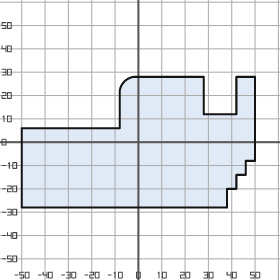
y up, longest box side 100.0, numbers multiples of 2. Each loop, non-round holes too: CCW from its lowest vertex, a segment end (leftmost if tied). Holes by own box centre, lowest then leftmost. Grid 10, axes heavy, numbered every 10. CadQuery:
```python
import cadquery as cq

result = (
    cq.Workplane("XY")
    .moveTo(-50.0, -28.0)
    .lineTo(38.0, -28.0)
    .lineTo(38.0, -20.0)
    .lineTo(42.0, -20.0)
    .lineTo(42.0, -14.0)
    .lineTo(46.0, -14.0)
    .lineTo(46.0, -8.0)
    .lineTo(50.0, -8.0)
    .lineTo(50.0, 28.0)
    .lineTo(42.0, 28.0)
    .lineTo(42.0, 12.0)
    .lineTo(28.0, 12.0)
    .lineTo(28.0, 28.0)
    .lineTo(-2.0, 28.0)
    .threePointArc((-6.0, 26.0), (-8.0, 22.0))
    .lineTo(-8.0, 6.0)
    .lineTo(-50.0, 6.0)
    .close()
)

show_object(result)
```